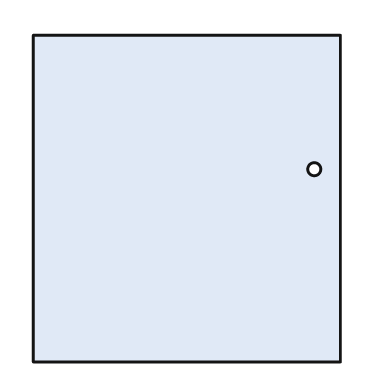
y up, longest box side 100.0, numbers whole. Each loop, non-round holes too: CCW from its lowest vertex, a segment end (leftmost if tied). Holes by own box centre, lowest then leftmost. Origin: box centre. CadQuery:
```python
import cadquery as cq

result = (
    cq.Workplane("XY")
    .moveTo(-47.0, -50.0)
    .lineTo(47.0, -50.0)
    .lineTo(47.0, 50.0)
    .lineTo(-47.0, 50.0)
    .close()
    .moveTo(39.0, 9.0)
    .circle(2.0)
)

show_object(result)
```